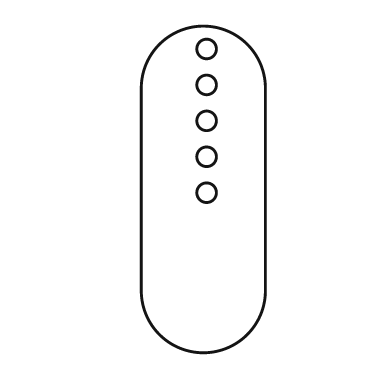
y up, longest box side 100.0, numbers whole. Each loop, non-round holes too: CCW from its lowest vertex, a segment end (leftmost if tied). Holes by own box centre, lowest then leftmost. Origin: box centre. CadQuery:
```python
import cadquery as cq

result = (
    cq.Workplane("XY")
    .moveTo(-19.0, -31.0)
    .threePointArc((0.0, -50.0), (19.0, -31.0))
    .lineTo(19.0, 31.0)
    .threePointArc((0.0, 50.0), (-19.0, 31.0))
    .close()
    .moveTo(1.0, -1.0)
    .circle(3.0)
    .moveTo(1.0, 10.0)
    .circle(3.0)
    .moveTo(1.0, 21.0)
    .circle(3.0)
    .moveTo(1.0, 32.0)
    .circle(3.0)
    .moveTo(1.0, 43.0)
    .circle(3.0)
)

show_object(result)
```